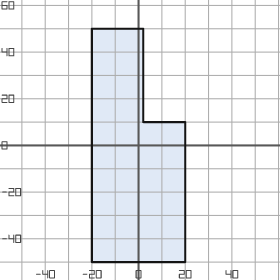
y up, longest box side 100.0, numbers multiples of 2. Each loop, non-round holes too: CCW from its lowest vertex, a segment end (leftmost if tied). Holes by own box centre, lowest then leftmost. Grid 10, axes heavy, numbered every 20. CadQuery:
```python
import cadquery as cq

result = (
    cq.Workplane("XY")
    .moveTo(-20.0, -50.0)
    .lineTo(20.0, -50.0)
    .lineTo(20.0, 10.0)
    .lineTo(2.0, 10.0)
    .lineTo(2.0, 50.0)
    .lineTo(-20.0, 50.0)
    .close()
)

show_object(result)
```